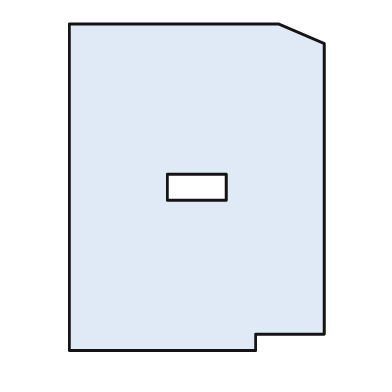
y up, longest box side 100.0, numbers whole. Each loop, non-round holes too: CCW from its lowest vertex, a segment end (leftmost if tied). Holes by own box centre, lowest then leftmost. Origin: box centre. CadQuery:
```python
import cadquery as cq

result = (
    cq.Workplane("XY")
    .moveTo(-39.0, -50.0)
    .lineTo(18.0, -50.0)
    .lineTo(18.0, -45.0)
    .lineTo(39.0, -45.0)
    .lineTo(39.0, 44.0)
    .lineTo(25.0, 50.0)
    .lineTo(-39.0, 50.0)
    .close()
    .moveTo(-9.0, -4.0)
    .lineTo(9.0, -4.0)
    .lineTo(9.0, 4.0)
    .lineTo(-9.0, 4.0)
    .close()
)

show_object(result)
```